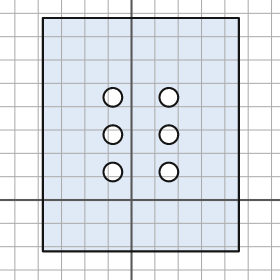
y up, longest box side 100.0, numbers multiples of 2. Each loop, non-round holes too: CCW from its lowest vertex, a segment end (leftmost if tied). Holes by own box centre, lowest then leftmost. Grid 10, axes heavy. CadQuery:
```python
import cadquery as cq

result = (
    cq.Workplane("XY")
    .moveTo(-38.0, -22.0)
    .lineTo(46.0, -22.0)
    .lineTo(46.0, 78.0)
    .lineTo(-38.0, 78.0)
    .close()
    .moveTo(-8.0, 12.0)
    .circle(4.0)
    .moveTo(16.0, 12.0)
    .circle(4.0)
    .moveTo(-8.0, 28.0)
    .circle(4.0)
    .moveTo(16.0, 28.0)
    .circle(4.0)
    .moveTo(-8.0, 44.0)
    .circle(4.0)
    .moveTo(16.0, 44.0)
    .circle(4.0)
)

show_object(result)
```